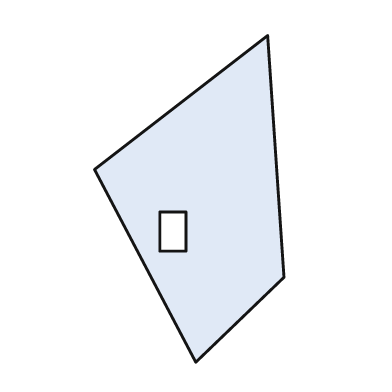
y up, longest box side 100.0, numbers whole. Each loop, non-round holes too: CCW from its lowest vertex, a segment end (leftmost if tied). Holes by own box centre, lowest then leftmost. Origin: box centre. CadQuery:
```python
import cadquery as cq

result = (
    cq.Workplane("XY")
    .moveTo(2.0, -50.0)
    .lineTo(29.0, -24.0)
    .lineTo(24.0, 50.0)
    .lineTo(-29.0, 9.0)
    .close()
    .moveTo(-9.0, -16.0)
    .lineTo(-1.0, -16.0)
    .lineTo(-1.0, -4.0)
    .lineTo(-9.0, -4.0)
    .close()
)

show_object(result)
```